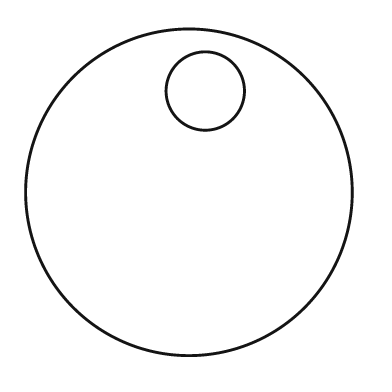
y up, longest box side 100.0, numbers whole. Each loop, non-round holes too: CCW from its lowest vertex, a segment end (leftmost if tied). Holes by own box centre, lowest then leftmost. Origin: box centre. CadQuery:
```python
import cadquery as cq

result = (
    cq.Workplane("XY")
    .moveTo(0.0, 0.0)
    .circle(50.0)
    .moveTo(5.0, 31.0)
    .circle(12.0)
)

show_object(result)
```